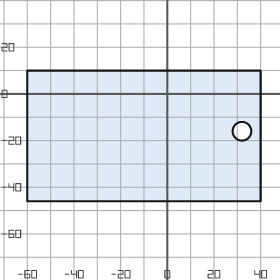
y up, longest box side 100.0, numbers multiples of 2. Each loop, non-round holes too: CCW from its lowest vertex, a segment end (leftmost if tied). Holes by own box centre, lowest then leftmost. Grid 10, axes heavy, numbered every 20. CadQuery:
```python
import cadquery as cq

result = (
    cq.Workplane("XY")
    .moveTo(-60.0, -46.0)
    .lineTo(40.0, -46.0)
    .lineTo(40.0, 10.0)
    .lineTo(-60.0, 10.0)
    .close()
    .moveTo(32.0, -16.0)
    .circle(4.0)
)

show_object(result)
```